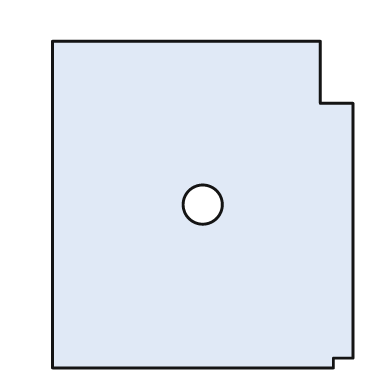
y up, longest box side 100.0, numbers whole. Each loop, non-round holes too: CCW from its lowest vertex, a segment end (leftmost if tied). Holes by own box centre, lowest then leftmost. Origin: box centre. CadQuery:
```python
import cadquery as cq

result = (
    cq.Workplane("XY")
    .moveTo(-46.0, -50.0)
    .lineTo(40.0, -50.0)
    .lineTo(40.0, -47.0)
    .lineTo(46.0, -47.0)
    .lineTo(46.0, 31.0)
    .lineTo(36.0, 31.0)
    .lineTo(36.0, 50.0)
    .lineTo(-46.0, 50.0)
    .close()
    .moveTo(0.0, 0.0)
    .circle(6.0)
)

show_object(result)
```